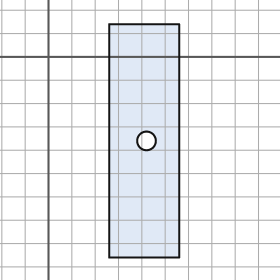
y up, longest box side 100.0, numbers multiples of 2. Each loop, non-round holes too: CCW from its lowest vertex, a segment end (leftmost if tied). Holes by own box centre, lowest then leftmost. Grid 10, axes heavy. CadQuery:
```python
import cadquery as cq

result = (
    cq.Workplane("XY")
    .moveTo(26.0, -86.0)
    .lineTo(56.0, -86.0)
    .lineTo(56.0, 14.0)
    .lineTo(26.0, 14.0)
    .close()
    .moveTo(42.0, -36.0)
    .circle(4.0)
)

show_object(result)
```